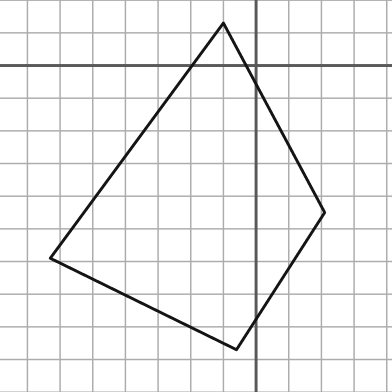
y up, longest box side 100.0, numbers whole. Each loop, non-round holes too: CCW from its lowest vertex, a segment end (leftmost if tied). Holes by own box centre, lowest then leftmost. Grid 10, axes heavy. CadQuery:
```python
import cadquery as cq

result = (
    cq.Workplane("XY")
    .moveTo(-6.0, -87.0)
    .lineTo(21.0, -45.0)
    .lineTo(-10.0, 13.0)
    .lineTo(-63.0, -59.0)
    .close()
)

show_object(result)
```